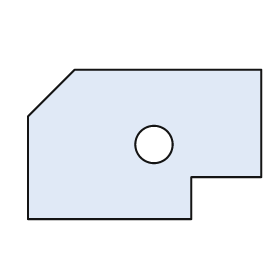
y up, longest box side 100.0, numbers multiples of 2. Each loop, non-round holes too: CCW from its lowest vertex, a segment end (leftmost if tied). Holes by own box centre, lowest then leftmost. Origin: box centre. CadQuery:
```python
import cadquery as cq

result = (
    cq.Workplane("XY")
    .moveTo(-50.0, -32.0)
    .lineTo(20.0, -32.0)
    .lineTo(20.0, -14.0)
    .lineTo(50.0, -14.0)
    .lineTo(50.0, 32.0)
    .lineTo(-30.0, 32.0)
    .lineTo(-50.0, 12.0)
    .close()
    .moveTo(4.0, 0.0)
    .circle(8.0)
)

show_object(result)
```